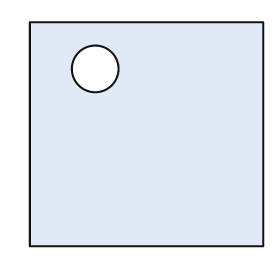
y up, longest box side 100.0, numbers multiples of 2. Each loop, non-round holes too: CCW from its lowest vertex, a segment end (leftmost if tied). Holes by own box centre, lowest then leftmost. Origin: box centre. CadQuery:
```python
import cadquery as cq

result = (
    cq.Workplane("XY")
    .moveTo(-50.0, -48.0)
    .lineTo(50.0, -48.0)
    .lineTo(50.0, 48.0)
    .lineTo(-50.0, 48.0)
    .close()
    .moveTo(-22.0, 28.0)
    .circle(10.0)
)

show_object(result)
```